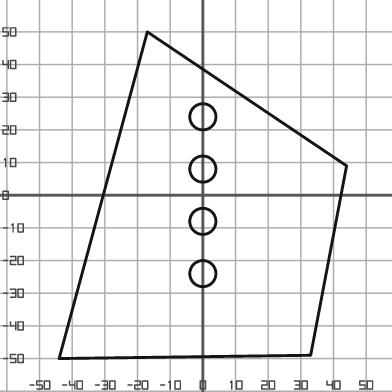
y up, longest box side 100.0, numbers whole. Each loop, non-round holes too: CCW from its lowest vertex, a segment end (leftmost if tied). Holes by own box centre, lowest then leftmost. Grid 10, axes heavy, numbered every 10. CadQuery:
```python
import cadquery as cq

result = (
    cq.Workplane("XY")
    .moveTo(-44.0, -50.0)
    .lineTo(33.0, -49.0)
    .lineTo(44.0, 9.0)
    .lineTo(-17.0, 50.0)
    .close()
    .moveTo(0.0, -24.0)
    .circle(4.0)
    .moveTo(0.0, -8.0)
    .circle(4.0)
    .moveTo(0.0, 8.0)
    .circle(4.0)
    .moveTo(0.0, 24.0)
    .circle(4.0)
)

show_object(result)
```